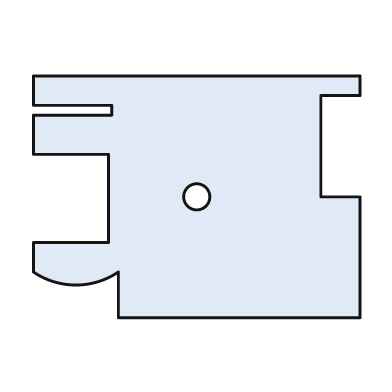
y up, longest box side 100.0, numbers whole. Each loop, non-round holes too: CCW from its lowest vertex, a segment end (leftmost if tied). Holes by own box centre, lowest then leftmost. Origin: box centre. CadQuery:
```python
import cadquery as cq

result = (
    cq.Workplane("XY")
    .moveTo(-24.0, -37.0)
    .lineTo(50.0, -37.0)
    .lineTo(50.0, 0.0)
    .lineTo(38.0, 0.0)
    .lineTo(38.0, 31.0)
    .lineTo(50.0, 31.0)
    .lineTo(50.0, 37.0)
    .lineTo(-50.0, 37.0)
    .lineTo(-50.0, 28.0)
    .lineTo(-26.0, 28.0)
    .lineTo(-26.0, 25.0)
    .lineTo(-50.0, 25.0)
    .lineTo(-50.0, 13.0)
    .lineTo(-27.0, 13.0)
    .lineTo(-27.0, -14.0)
    .lineTo(-50.0, -14.0)
    .lineTo(-50.0, -23.0)
    .threePointArc((-37.0, -27.0), (-24.0, -23.0))
    .close()
    .moveTo(0.0, 0.0)
    .circle(4.0)
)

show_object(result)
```